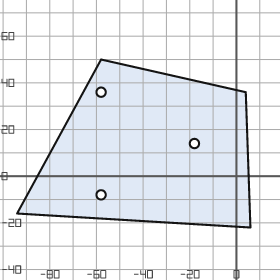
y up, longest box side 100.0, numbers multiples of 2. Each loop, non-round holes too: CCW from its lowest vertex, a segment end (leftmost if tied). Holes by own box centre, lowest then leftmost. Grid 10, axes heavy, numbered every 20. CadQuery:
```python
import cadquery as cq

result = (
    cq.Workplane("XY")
    .moveTo(6.0, -22.0)
    .lineTo(4.0, 36.0)
    .lineTo(-58.0, 50.0)
    .lineTo(-94.0, -16.0)
    .close()
    .moveTo(-58.0, -8.0)
    .circle(2.0)
    .moveTo(-18.0, 14.0)
    .circle(2.0)
    .moveTo(-58.0, 36.0)
    .circle(2.0)
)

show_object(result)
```